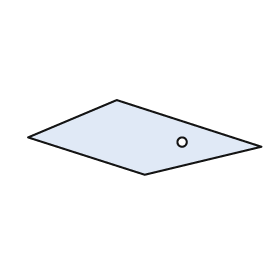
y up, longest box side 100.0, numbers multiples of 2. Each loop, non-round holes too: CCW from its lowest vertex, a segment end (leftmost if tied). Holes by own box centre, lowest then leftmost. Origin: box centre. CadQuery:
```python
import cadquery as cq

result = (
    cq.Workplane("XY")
    .moveTo(0.0, -16.0)
    .lineTo(50.0, -4.0)
    .lineTo(-12.0, 16.0)
    .lineTo(-50.0, 0.0)
    .close()
    .moveTo(16.0, -2.0)
    .circle(2.0)
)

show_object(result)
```